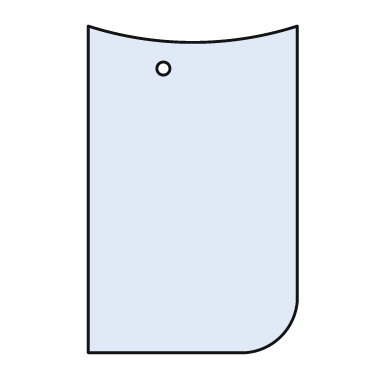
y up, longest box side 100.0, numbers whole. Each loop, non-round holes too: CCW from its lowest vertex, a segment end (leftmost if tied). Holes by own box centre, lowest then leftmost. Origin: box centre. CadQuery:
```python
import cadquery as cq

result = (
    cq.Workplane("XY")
    .moveTo(-32.0, -50.0)
    .lineTo(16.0, -50.0)
    .threePointArc((27.0, -45.0), (32.0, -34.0))
    .lineTo(32.0, 50.0)
    .threePointArc((0.0, 45.0), (-32.0, 50.0))
    .close()
    .moveTo(-9.0, 37.0)
    .circle(2.0)
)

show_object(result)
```